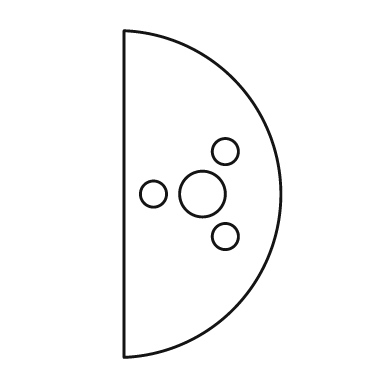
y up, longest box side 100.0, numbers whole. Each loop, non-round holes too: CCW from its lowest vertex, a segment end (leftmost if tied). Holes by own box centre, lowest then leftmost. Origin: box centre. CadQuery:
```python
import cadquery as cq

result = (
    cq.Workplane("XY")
    .moveTo(-24.0, -50.0)
    .threePointArc((24.0, 0.0), (-24.0, 50.0))
    .close()
    .moveTo(7.0, -13.0)
    .circle(4.0)
    .moveTo(-15.0, 0.0)
    .circle(4.0)
    .moveTo(0.0, 0.0)
    .circle(7.0)
    .moveTo(7.0, 13.0)
    .circle(4.0)
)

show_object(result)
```